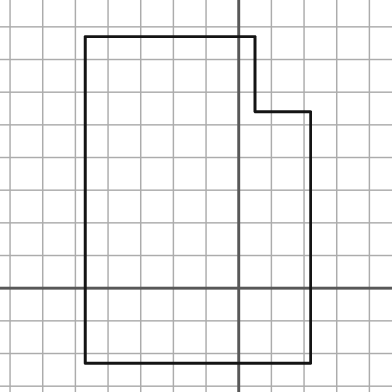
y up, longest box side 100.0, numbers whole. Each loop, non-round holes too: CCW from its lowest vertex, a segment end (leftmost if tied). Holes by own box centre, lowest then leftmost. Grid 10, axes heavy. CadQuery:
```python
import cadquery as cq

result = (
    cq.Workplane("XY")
    .moveTo(-47.0, -23.0)
    .lineTo(22.0, -23.0)
    .lineTo(22.0, 54.0)
    .lineTo(5.0, 54.0)
    .lineTo(5.0, 77.0)
    .lineTo(-47.0, 77.0)
    .close()
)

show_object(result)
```